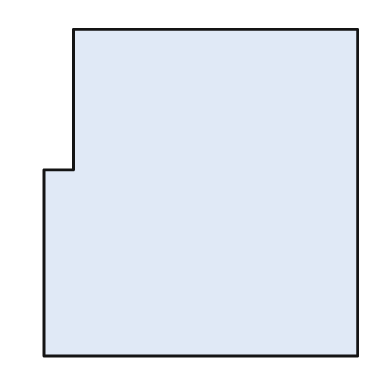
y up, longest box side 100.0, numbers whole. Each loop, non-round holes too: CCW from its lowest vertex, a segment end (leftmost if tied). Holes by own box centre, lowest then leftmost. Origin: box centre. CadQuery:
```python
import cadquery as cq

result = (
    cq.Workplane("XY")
    .moveTo(-48.0, -50.0)
    .lineTo(48.0, -50.0)
    .lineTo(48.0, 50.0)
    .lineTo(-39.0, 50.0)
    .lineTo(-39.0, 7.0)
    .lineTo(-48.0, 7.0)
    .close()
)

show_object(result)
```